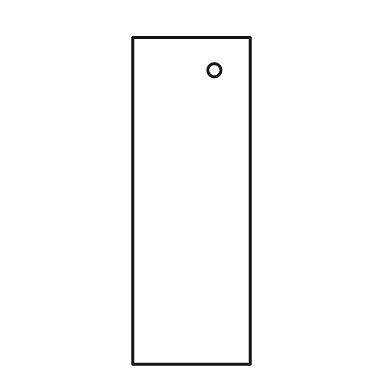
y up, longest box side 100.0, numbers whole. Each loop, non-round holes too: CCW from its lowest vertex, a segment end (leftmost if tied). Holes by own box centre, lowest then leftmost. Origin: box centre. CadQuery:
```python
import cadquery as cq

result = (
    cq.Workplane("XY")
    .moveTo(-18.0, -50.0)
    .lineTo(18.0, -50.0)
    .lineTo(18.0, 50.0)
    .lineTo(-18.0, 50.0)
    .close()
    .moveTo(7.0, 40.0)
    .circle(2.0)
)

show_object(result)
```